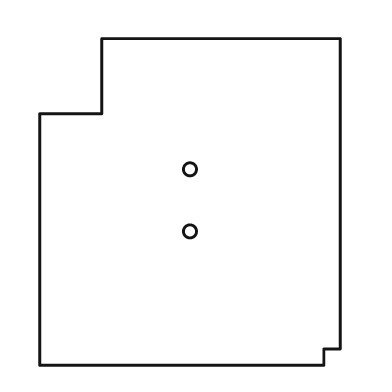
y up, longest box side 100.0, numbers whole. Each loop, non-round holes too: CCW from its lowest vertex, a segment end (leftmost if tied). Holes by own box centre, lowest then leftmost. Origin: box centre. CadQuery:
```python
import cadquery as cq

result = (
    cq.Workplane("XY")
    .moveTo(-46.0, -50.0)
    .lineTo(41.0, -50.0)
    .lineTo(41.0, -45.0)
    .lineTo(46.0, -45.0)
    .lineTo(46.0, 50.0)
    .lineTo(-27.0, 50.0)
    .lineTo(-27.0, 27.0)
    .lineTo(-46.0, 27.0)
    .close()
    .moveTo(0.0, -9.0)
    .circle(2.0)
    .moveTo(0.0, 10.0)
    .circle(2.0)
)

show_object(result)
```